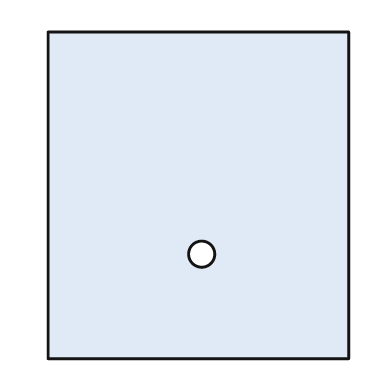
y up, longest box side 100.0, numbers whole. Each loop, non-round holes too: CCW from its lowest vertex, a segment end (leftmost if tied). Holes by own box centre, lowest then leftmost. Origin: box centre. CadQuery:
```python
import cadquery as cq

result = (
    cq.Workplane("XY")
    .moveTo(-46.0, -50.0)
    .lineTo(46.0, -50.0)
    .lineTo(46.0, 50.0)
    .lineTo(-46.0, 50.0)
    .close()
    .moveTo(1.0, -18.0)
    .circle(4.0)
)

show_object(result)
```